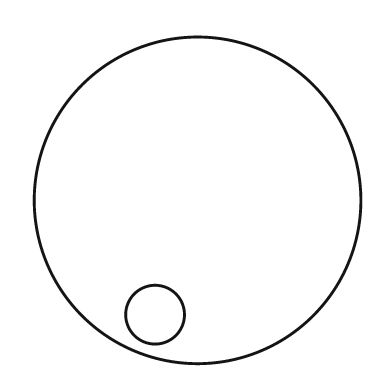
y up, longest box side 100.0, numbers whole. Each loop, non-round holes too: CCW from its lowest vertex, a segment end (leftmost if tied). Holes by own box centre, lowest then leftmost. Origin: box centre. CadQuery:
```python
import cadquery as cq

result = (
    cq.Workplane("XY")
    .moveTo(0.0, 0.0)
    .circle(50.0)
    .moveTo(-13.0, -35.0)
    .circle(9.0)
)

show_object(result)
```